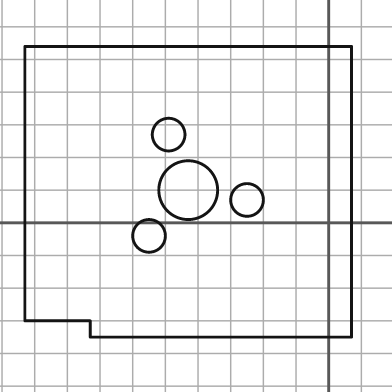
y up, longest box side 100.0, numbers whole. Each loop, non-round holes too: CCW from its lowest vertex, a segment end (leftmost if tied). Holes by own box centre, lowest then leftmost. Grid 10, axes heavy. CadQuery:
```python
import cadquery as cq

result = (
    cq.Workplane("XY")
    .moveTo(-73.0, -35.0)
    .lineTo(7.0, -35.0)
    .lineTo(7.0, 54.0)
    .lineTo(-93.0, 54.0)
    .lineTo(-93.0, -30.0)
    .lineTo(-73.0, -30.0)
    .close()
    .moveTo(-55.0, -4.0)
    .circle(5.0)
    .moveTo(-25.0, 7.0)
    .circle(5.0)
    .moveTo(-43.0, 10.0)
    .circle(9.0)
    .moveTo(-49.0, 27.0)
    .circle(5.0)
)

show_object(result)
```